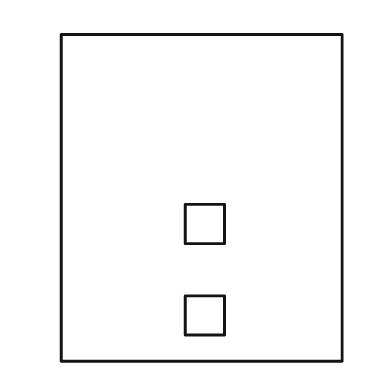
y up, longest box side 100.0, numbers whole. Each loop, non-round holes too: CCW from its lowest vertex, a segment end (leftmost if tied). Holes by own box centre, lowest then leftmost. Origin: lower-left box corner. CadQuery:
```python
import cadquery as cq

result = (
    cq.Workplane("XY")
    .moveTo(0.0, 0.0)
    .lineTo(86.0, 0.0)
    .lineTo(86.0, 100.0)
    .lineTo(0.0, 100.0)
    .close()
    .moveTo(38.0, 8.0)
    .lineTo(50.0, 8.0)
    .lineTo(50.0, 20.0)
    .lineTo(38.0, 20.0)
    .close()
    .moveTo(38.0, 36.0)
    .lineTo(50.0, 36.0)
    .lineTo(50.0, 48.0)
    .lineTo(38.0, 48.0)
    .close()
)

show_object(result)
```